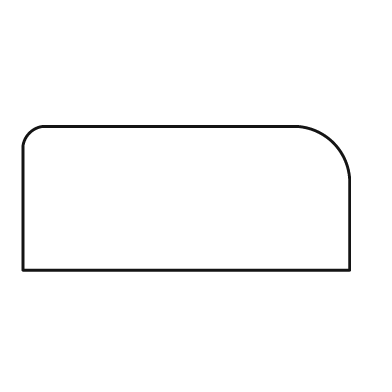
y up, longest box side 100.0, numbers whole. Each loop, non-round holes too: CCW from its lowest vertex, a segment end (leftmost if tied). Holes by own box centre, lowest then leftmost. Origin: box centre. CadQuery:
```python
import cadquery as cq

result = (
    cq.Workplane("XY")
    .moveTo(-50.0, -22.0)
    .lineTo(50.0, -22.0)
    .lineTo(50.0, 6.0)
    .threePointArc((45.0, 17.0), (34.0, 22.0))
    .lineTo(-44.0, 22.0)
    .threePointArc((-48.0, 20.0), (-50.0, 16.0))
    .close()
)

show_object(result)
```